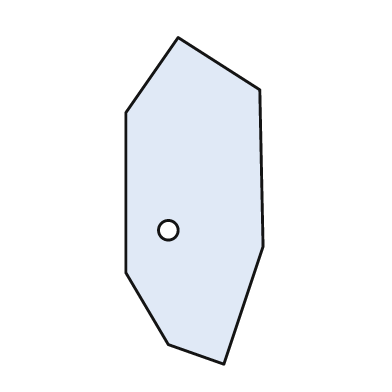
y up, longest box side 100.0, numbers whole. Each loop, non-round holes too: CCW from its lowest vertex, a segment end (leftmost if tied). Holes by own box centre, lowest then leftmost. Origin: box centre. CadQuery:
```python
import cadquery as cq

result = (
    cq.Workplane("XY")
    .moveTo(9.0, -50.0)
    .lineTo(21.0, -14.0)
    .lineTo(20.0, 34.0)
    .lineTo(-5.0, 50.0)
    .lineTo(-21.0, 27.0)
    .lineTo(-21.0, -22.0)
    .lineTo(-8.0, -44.0)
    .close()
    .moveTo(-8.0, -9.0)
    .circle(3.0)
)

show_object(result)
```